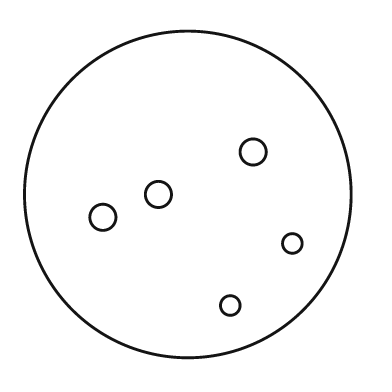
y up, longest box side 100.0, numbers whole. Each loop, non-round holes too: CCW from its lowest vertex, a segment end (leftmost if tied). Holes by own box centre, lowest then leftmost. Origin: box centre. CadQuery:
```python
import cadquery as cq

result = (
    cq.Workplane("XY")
    .moveTo(0.0, 0.0)
    .circle(50.0)
    .moveTo(13.0, -34.0)
    .circle(3.0)
    .moveTo(32.0, -15.0)
    .circle(3.0)
    .moveTo(-26.0, -7.0)
    .circle(4.0)
    .moveTo(-9.0, 0.0)
    .circle(4.0)
    .moveTo(20.0, 13.0)
    .circle(4.0)
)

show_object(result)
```